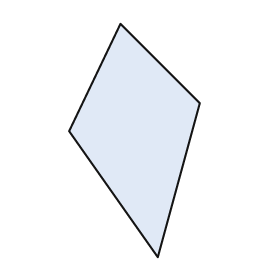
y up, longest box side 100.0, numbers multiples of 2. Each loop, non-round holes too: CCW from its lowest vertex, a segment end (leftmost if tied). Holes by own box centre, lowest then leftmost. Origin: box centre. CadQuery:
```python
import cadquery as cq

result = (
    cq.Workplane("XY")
    .moveTo(10.0, -50.0)
    .lineTo(28.0, 16.0)
    .lineTo(-6.0, 50.0)
    .lineTo(-28.0, 4.0)
    .close()
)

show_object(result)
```